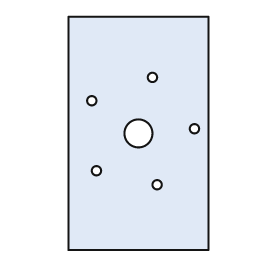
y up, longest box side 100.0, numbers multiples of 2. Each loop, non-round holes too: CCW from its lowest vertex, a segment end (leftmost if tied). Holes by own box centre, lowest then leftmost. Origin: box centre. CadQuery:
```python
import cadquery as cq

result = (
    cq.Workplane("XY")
    .moveTo(-30.0, -50.0)
    .lineTo(30.0, -50.0)
    .lineTo(30.0, 50.0)
    .lineTo(-30.0, 50.0)
    .close()
    .moveTo(8.0, -22.0)
    .circle(2.0)
    .moveTo(-18.0, -16.0)
    .circle(2.0)
    .moveTo(0.0, 0.0)
    .circle(6.0)
    .moveTo(24.0, 2.0)
    .circle(2.0)
    .moveTo(-20.0, 14.0)
    .circle(2.0)
    .moveTo(6.0, 24.0)
    .circle(2.0)
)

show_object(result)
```